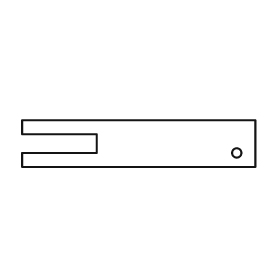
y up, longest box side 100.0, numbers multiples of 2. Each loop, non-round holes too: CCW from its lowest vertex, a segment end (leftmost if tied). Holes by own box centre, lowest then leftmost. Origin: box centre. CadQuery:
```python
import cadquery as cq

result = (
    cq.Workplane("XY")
    .moveTo(-50.0, -10.0)
    .lineTo(50.0, -10.0)
    .lineTo(50.0, 10.0)
    .lineTo(-50.0, 10.0)
    .lineTo(-50.0, 4.0)
    .lineTo(-18.0, 4.0)
    .lineTo(-18.0, -4.0)
    .lineTo(-50.0, -4.0)
    .close()
    .moveTo(42.0, -4.0)
    .circle(2.0)
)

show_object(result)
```